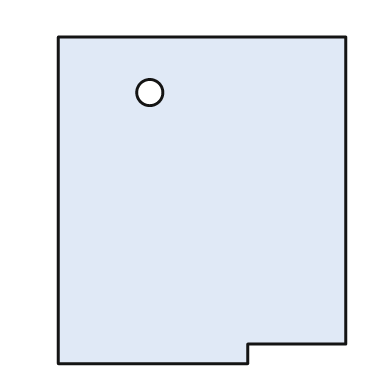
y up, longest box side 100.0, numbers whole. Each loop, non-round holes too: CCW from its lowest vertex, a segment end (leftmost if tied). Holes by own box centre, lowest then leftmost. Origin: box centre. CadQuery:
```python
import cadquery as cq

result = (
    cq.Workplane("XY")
    .moveTo(-44.0, -50.0)
    .lineTo(14.0, -50.0)
    .lineTo(14.0, -44.0)
    .lineTo(44.0, -44.0)
    .lineTo(44.0, 50.0)
    .lineTo(-44.0, 50.0)
    .close()
    .moveTo(-16.0, 33.0)
    .circle(4.0)
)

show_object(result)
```